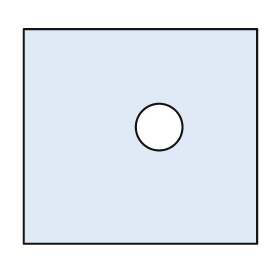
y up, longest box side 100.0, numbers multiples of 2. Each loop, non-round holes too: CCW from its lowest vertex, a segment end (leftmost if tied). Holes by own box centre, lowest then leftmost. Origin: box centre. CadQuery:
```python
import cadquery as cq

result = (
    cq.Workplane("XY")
    .moveTo(-50.0, -46.0)
    .lineTo(50.0, -46.0)
    .lineTo(50.0, 46.0)
    .lineTo(-50.0, 46.0)
    .close()
    .moveTo(8.0, 4.0)
    .circle(10.0)
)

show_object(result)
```